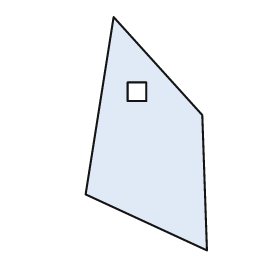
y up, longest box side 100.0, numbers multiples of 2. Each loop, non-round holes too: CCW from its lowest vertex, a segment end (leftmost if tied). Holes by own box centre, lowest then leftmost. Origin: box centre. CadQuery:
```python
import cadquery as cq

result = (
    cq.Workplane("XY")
    .moveTo(26.0, -50.0)
    .lineTo(24.0, 8.0)
    .lineTo(-14.0, 50.0)
    .lineTo(-26.0, -26.0)
    .close()
    .moveTo(-8.0, 14.0)
    .lineTo(0.0, 14.0)
    .lineTo(0.0, 22.0)
    .lineTo(-8.0, 22.0)
    .close()
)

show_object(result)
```